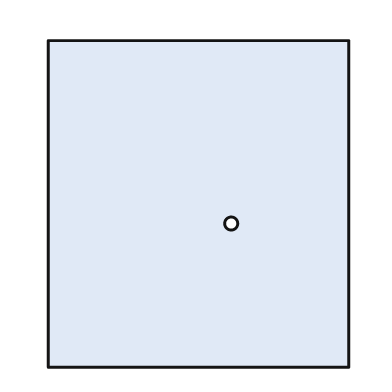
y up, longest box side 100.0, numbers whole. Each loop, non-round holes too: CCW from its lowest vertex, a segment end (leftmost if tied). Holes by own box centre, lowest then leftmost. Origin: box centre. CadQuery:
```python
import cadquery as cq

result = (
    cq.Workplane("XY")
    .moveTo(-46.0, -50.0)
    .lineTo(46.0, -50.0)
    .lineTo(46.0, 50.0)
    .lineTo(-46.0, 50.0)
    .close()
    .moveTo(10.0, -6.0)
    .circle(2.0)
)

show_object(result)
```